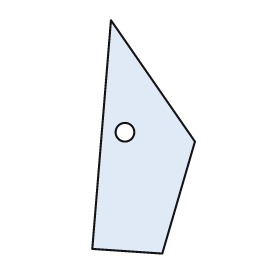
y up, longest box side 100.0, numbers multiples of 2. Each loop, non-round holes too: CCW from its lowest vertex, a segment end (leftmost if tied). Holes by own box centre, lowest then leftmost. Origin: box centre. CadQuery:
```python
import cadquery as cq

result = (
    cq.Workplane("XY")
    .moveTo(8.0, -50.0)
    .lineTo(22.0, -2.0)
    .lineTo(-14.0, 50.0)
    .lineTo(-22.0, -48.0)
    .close()
    .moveTo(-8.0, 2.0)
    .circle(4.0)
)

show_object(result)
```